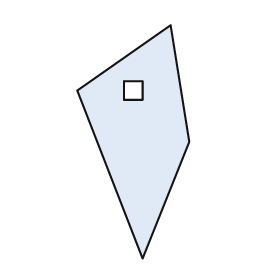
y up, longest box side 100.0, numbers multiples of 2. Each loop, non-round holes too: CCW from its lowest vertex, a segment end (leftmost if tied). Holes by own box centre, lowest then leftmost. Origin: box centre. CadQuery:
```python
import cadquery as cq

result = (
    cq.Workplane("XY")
    .moveTo(4.0, -50.0)
    .lineTo(24.0, 0.0)
    .lineTo(16.0, 50.0)
    .lineTo(-24.0, 22.0)
    .close()
    .moveTo(-4.0, 18.0)
    .lineTo(4.0, 18.0)
    .lineTo(4.0, 26.0)
    .lineTo(-4.0, 26.0)
    .close()
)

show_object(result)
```